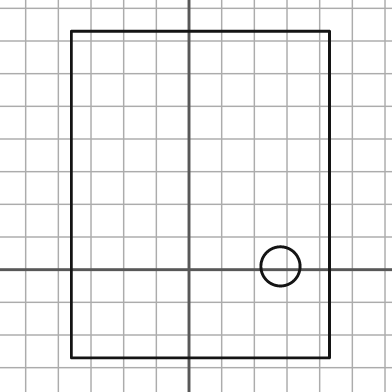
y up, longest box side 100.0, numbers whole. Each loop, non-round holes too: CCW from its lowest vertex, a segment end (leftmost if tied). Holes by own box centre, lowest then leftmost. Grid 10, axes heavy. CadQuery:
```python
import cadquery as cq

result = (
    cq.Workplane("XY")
    .moveTo(-36.0, -27.0)
    .lineTo(43.0, -27.0)
    .lineTo(43.0, 73.0)
    .lineTo(-36.0, 73.0)
    .close()
    .moveTo(28.0, 1.0)
    .circle(6.0)
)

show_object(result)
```